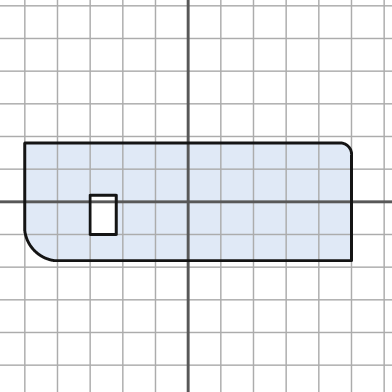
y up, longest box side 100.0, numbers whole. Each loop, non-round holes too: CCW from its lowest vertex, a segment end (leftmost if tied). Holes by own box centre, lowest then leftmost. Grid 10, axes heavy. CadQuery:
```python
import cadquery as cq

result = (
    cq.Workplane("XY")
    .moveTo(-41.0, -18.0)
    .lineTo(50.0, -18.0)
    .lineTo(50.0, 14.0)
    .threePointArc((49.0, 17.0), (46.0, 18.0))
    .lineTo(-50.0, 18.0)
    .lineTo(-50.0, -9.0)
    .threePointArc((-47.0, -15.0), (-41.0, -18.0))
    .close()
    .moveTo(-30.0, -10.0)
    .lineTo(-22.0, -10.0)
    .lineTo(-22.0, 2.0)
    .lineTo(-30.0, 2.0)
    .close()
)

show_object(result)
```